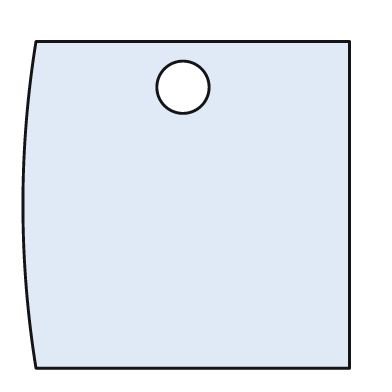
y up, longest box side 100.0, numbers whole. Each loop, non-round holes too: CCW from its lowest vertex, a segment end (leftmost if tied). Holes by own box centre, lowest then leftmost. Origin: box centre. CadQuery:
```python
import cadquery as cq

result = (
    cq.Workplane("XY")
    .moveTo(-46.0, -50.0)
    .lineTo(50.0, -50.0)
    .lineTo(50.0, 50.0)
    .lineTo(-46.0, 50.0)
    .threePointArc((-50.0, 0.0), (-46.0, -50.0))
    .close()
    .moveTo(-1.0, 36.0)
    .circle(8.0)
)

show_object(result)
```